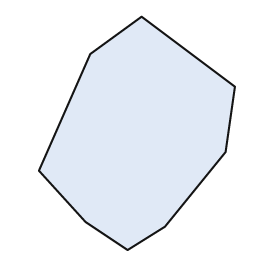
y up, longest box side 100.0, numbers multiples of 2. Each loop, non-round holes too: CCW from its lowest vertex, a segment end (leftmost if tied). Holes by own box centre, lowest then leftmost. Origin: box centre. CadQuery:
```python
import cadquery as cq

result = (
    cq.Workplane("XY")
    .moveTo(-4.0, -50.0)
    .lineTo(12.0, -40.0)
    .lineTo(38.0, -8.0)
    .lineTo(42.0, 20.0)
    .lineTo(2.0, 50.0)
    .lineTo(-20.0, 34.0)
    .lineTo(-42.0, -16.0)
    .lineTo(-22.0, -38.0)
    .close()
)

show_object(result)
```